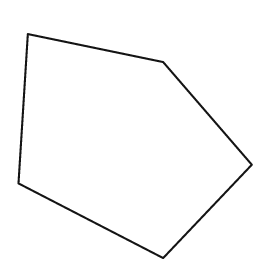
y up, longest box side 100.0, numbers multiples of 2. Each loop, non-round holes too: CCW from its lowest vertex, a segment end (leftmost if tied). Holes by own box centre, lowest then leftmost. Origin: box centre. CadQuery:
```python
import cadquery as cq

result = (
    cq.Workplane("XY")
    .moveTo(12.0, -48.0)
    .lineTo(50.0, -8.0)
    .lineTo(12.0, 36.0)
    .lineTo(-46.0, 48.0)
    .lineTo(-50.0, -16.0)
    .close()
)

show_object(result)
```